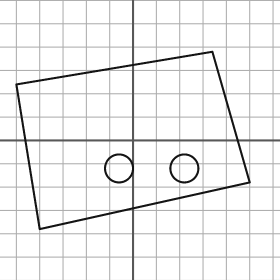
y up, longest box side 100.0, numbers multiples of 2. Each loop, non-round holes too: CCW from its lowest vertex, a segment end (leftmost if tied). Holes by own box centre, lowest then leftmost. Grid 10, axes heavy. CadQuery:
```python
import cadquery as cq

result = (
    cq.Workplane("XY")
    .moveTo(-40.0, -38.0)
    .lineTo(50.0, -18.0)
    .lineTo(34.0, 38.0)
    .lineTo(-50.0, 24.0)
    .close()
    .moveTo(-6.0, -12.0)
    .circle(6.0)
    .moveTo(22.0, -12.0)
    .circle(6.0)
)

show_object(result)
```